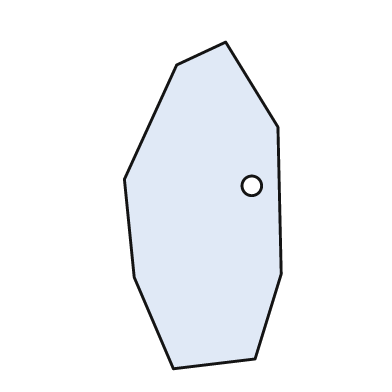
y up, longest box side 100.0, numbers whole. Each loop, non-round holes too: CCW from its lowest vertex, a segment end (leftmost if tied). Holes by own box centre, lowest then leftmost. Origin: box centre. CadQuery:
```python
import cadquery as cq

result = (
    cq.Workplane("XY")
    .moveTo(-9.0, -50.0)
    .lineTo(16.0, -47.0)
    .lineTo(24.0, -21.0)
    .lineTo(23.0, 24.0)
    .lineTo(7.0, 50.0)
    .lineTo(-8.0, 43.0)
    .lineTo(-24.0, 8.0)
    .lineTo(-21.0, -22.0)
    .close()
    .moveTo(15.0, 6.0)
    .circle(3.0)
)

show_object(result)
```